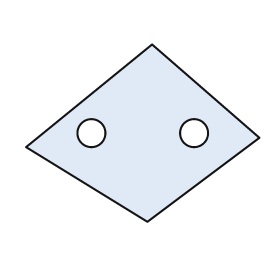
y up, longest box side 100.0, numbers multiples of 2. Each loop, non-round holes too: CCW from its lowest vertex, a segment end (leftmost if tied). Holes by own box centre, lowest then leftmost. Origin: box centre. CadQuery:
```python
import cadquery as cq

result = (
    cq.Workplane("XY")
    .moveTo(2.0, -38.0)
    .lineTo(50.0, -2.0)
    .lineTo(4.0, 38.0)
    .lineTo(-50.0, -6.0)
    .close()
    .moveTo(-22.0, 0.0)
    .circle(6.0)
    .moveTo(22.0, 0.0)
    .circle(6.0)
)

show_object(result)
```